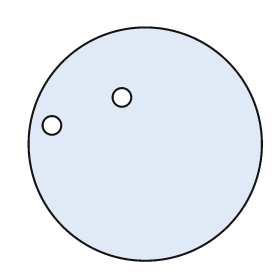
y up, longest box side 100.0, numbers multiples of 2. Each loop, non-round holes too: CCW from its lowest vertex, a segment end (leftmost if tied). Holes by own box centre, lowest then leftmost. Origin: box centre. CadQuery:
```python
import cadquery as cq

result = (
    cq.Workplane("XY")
    .moveTo(0.0, 0.0)
    .circle(50.0)
    .moveTo(-40.0, 8.0)
    .circle(4.0)
    .moveTo(-10.0, 20.0)
    .circle(4.0)
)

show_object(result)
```